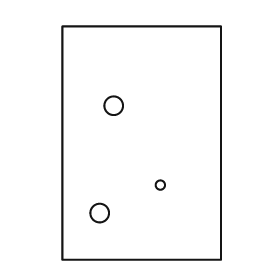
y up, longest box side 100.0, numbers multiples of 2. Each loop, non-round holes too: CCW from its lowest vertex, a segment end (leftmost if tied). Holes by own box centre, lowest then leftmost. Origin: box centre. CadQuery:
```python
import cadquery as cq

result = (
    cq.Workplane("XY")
    .moveTo(-34.0, -50.0)
    .lineTo(34.0, -50.0)
    .lineTo(34.0, 50.0)
    .lineTo(-34.0, 50.0)
    .close()
    .moveTo(-18.0, -30.0)
    .circle(4.0)
    .moveTo(8.0, -18.0)
    .circle(2.0)
    .moveTo(-12.0, 16.0)
    .circle(4.0)
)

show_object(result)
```